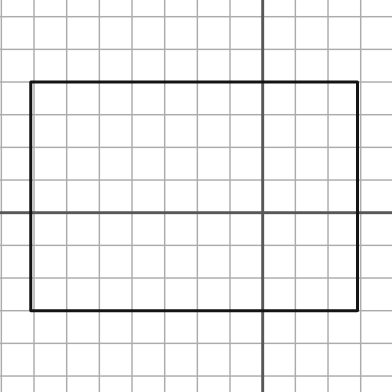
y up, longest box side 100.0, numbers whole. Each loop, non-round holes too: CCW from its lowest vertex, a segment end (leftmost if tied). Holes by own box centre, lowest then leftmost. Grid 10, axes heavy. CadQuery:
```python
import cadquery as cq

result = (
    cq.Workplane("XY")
    .moveTo(-71.0, -30.0)
    .lineTo(29.0, -30.0)
    .lineTo(29.0, 40.0)
    .lineTo(-71.0, 40.0)
    .close()
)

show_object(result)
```